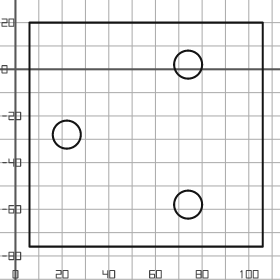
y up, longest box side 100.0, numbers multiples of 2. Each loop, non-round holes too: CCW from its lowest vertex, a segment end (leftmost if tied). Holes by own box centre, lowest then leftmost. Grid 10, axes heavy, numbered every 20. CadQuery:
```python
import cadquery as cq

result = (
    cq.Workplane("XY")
    .moveTo(6.0, -76.0)
    .lineTo(106.0, -76.0)
    .lineTo(106.0, 20.0)
    .lineTo(6.0, 20.0)
    .close()
    .moveTo(74.0, -58.0)
    .circle(6.0)
    .moveTo(22.0, -28.0)
    .circle(6.0)
    .moveTo(74.0, 2.0)
    .circle(6.0)
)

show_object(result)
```